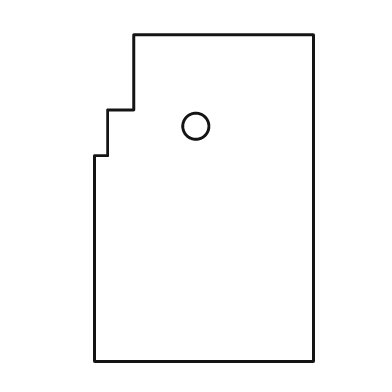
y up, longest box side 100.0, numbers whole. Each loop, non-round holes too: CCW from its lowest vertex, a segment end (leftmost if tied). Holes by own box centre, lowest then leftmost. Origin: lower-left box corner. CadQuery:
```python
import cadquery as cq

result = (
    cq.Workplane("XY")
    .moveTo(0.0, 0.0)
    .lineTo(67.0, 0.0)
    .lineTo(67.0, 100.0)
    .lineTo(12.0, 100.0)
    .lineTo(12.0, 77.0)
    .lineTo(4.0, 77.0)
    .lineTo(4.0, 63.0)
    .lineTo(0.0, 63.0)
    .close()
    .moveTo(31.0, 72.0)
    .circle(4.0)
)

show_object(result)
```